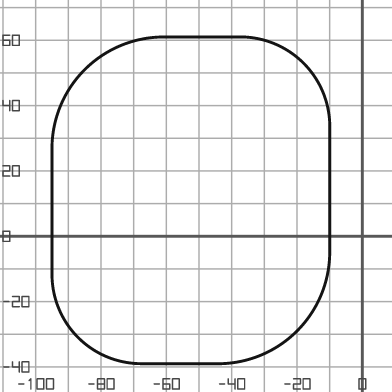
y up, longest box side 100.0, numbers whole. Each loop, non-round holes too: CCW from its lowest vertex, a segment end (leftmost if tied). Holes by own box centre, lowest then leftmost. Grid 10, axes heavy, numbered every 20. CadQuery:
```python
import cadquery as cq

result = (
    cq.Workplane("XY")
    .moveTo(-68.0, -39.0)
    .lineTo(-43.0, -39.0)
    .threePointArc((-20.0, -29.0), (-10.0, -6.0))
    .lineTo(-10.0, 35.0)
    .threePointArc((-18.0, 53.0), (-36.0, 61.0))
    .lineTo(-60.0, 61.0)
    .threePointArc((-85.0, 51.0), (-95.0, 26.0))
    .lineTo(-95.0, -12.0)
    .threePointArc((-87.0, -31.0), (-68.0, -39.0))
    .close()
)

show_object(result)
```